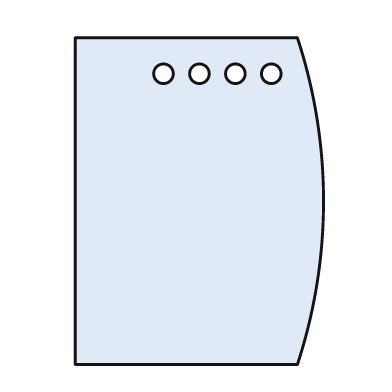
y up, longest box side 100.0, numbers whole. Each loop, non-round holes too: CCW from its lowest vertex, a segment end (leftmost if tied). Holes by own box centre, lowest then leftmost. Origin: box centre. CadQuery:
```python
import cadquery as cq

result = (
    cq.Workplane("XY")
    .moveTo(-38.0, -50.0)
    .lineTo(30.0, -50.0)
    .threePointArc((38.0, 0.0), (30.0, 50.0))
    .lineTo(-38.0, 50.0)
    .close()
    .moveTo(-11.0, 39.0)
    .circle(3.0)
    .moveTo(0.0, 39.0)
    .circle(3.0)
    .moveTo(11.0, 39.0)
    .circle(3.0)
    .moveTo(22.0, 39.0)
    .circle(3.0)
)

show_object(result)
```